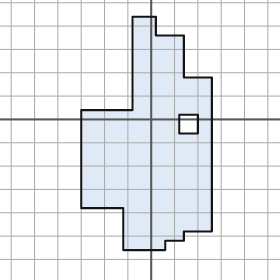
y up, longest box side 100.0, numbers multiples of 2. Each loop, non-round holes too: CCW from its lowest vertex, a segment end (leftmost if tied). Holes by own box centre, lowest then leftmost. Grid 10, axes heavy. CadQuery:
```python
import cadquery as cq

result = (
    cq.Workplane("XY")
    .moveTo(-12.0, -56.0)
    .lineTo(6.0, -56.0)
    .lineTo(6.0, -52.0)
    .lineTo(14.0, -52.0)
    .lineTo(14.0, -48.0)
    .lineTo(26.0, -48.0)
    .lineTo(26.0, 18.0)
    .lineTo(14.0, 18.0)
    .lineTo(14.0, 36.0)
    .lineTo(2.0, 36.0)
    .lineTo(2.0, 44.0)
    .lineTo(-8.0, 44.0)
    .lineTo(-8.0, 4.0)
    .lineTo(-30.0, 4.0)
    .lineTo(-30.0, -38.0)
    .lineTo(-12.0, -38.0)
    .close()
    .moveTo(12.0, -6.0)
    .lineTo(20.0, -6.0)
    .lineTo(20.0, 2.0)
    .lineTo(12.0, 2.0)
    .close()
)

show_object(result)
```